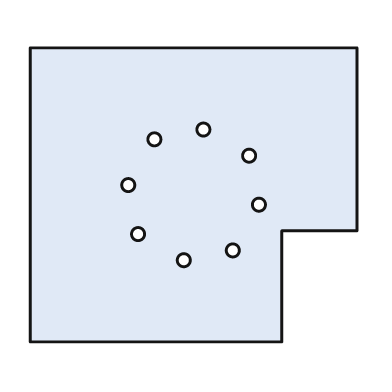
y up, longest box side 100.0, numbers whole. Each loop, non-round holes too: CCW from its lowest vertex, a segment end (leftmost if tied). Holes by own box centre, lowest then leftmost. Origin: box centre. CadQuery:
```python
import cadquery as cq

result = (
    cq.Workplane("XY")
    .moveTo(-50.0, -45.0)
    .lineTo(27.0, -45.0)
    .lineTo(27.0, -11.0)
    .lineTo(50.0, -11.0)
    .lineTo(50.0, 45.0)
    .lineTo(-50.0, 45.0)
    .close()
    .moveTo(-3.0, -20.0)
    .circle(2.0)
    .moveTo(12.0, -17.0)
    .circle(2.0)
    .moveTo(-17.0, -12.0)
    .circle(2.0)
    .moveTo(20.0, -3.0)
    .circle(2.0)
    .moveTo(-20.0, 3.0)
    .circle(2.0)
    .moveTo(17.0, 12.0)
    .circle(2.0)
    .moveTo(-12.0, 17.0)
    .circle(2.0)
    .moveTo(3.0, 20.0)
    .circle(2.0)
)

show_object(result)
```